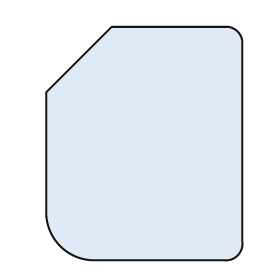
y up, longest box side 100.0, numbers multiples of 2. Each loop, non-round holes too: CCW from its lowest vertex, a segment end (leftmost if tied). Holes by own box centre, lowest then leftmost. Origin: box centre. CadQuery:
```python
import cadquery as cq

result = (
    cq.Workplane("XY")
    .moveTo(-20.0, -50.0)
    .lineTo(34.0, -50.0)
    .threePointArc((40.0, -48.0), (42.0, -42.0))
    .lineTo(42.0, 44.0)
    .threePointArc((40.0, 48.0), (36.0, 50.0))
    .lineTo(-14.0, 50.0)
    .lineTo(-42.0, 22.0)
    .lineTo(-42.0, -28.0)
    .threePointArc((-36.0, -44.0), (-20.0, -50.0))
    .close()
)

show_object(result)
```